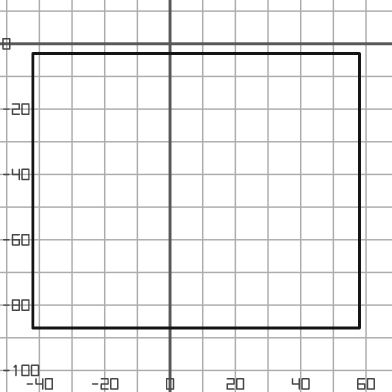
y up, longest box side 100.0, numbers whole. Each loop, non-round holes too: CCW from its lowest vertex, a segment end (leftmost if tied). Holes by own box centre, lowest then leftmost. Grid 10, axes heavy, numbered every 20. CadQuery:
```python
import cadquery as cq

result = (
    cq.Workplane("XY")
    .moveTo(-42.0, -87.0)
    .lineTo(58.0, -87.0)
    .lineTo(58.0, -3.0)
    .lineTo(-42.0, -3.0)
    .close()
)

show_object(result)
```